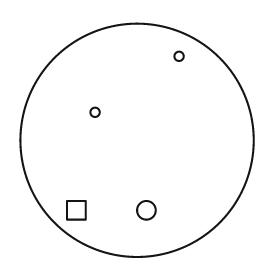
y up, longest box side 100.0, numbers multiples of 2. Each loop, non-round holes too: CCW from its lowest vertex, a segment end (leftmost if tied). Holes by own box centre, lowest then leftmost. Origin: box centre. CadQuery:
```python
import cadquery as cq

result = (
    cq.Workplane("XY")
    .moveTo(0.0, 0.0)
    .circle(50.0)
    .moveTo(-30.0, -34.0)
    .lineTo(-22.0, -34.0)
    .lineTo(-22.0, -26.0)
    .lineTo(-30.0, -26.0)
    .close()
    .moveTo(4.0, -30.0)
    .circle(4.0)
    .moveTo(-18.0, 12.0)
    .circle(2.0)
    .moveTo(18.0, 36.0)
    .circle(2.0)
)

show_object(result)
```